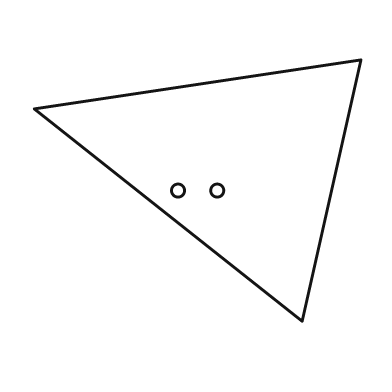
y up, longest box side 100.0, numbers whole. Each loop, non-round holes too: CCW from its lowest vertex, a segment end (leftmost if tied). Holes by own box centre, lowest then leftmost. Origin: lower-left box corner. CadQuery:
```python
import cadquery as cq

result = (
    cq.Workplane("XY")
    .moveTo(82.0, 0.0)
    .lineTo(100.0, 80.0)
    .lineTo(0.0, 65.0)
    .close()
    .moveTo(44.0, 40.0)
    .circle(2.0)
    .moveTo(56.0, 40.0)
    .circle(2.0)
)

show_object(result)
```